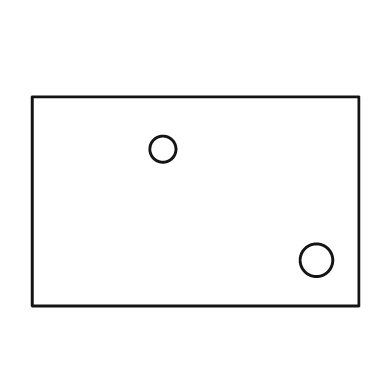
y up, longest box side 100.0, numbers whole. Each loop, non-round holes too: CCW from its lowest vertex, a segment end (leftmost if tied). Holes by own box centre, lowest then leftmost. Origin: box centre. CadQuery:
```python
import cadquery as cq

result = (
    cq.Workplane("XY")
    .moveTo(-50.0, -32.0)
    .lineTo(50.0, -32.0)
    .lineTo(50.0, 32.0)
    .lineTo(-50.0, 32.0)
    .close()
    .moveTo(37.0, -18.0)
    .circle(5.0)
    .moveTo(-10.0, 16.0)
    .circle(4.0)
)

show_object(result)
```